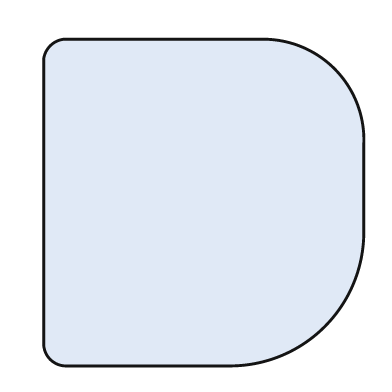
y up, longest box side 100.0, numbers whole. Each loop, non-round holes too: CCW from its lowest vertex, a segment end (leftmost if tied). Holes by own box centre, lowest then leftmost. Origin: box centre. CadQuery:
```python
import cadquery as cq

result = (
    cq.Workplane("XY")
    .moveTo(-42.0, -50.0)
    .lineTo(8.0, -50.0)
    .threePointArc((37.0, -38.0), (49.0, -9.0))
    .lineTo(49.0, 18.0)
    .threePointArc((40.0, 41.0), (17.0, 50.0))
    .lineTo(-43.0, 50.0)
    .threePointArc((-47.0, 48.0), (-49.0, 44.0))
    .lineTo(-49.0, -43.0)
    .threePointArc((-47.0, -48.0), (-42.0, -50.0))
    .close()
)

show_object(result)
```